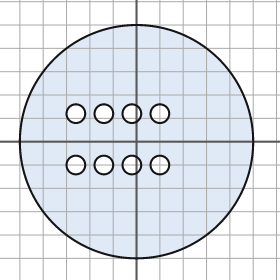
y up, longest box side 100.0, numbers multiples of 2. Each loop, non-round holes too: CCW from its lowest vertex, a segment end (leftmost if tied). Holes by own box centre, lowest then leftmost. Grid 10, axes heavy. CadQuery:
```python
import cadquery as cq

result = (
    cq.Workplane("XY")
    .moveTo(0.0, 0.0)
    .circle(50.0)
    .moveTo(-26.0, -10.0)
    .circle(4.0)
    .moveTo(-14.0, -10.0)
    .circle(4.0)
    .moveTo(-2.0, -10.0)
    .circle(4.0)
    .moveTo(10.0, -10.0)
    .circle(4.0)
    .moveTo(-26.0, 12.0)
    .circle(4.0)
    .moveTo(-14.0, 12.0)
    .circle(4.0)
    .moveTo(-2.0, 12.0)
    .circle(4.0)
    .moveTo(10.0, 12.0)
    .circle(4.0)
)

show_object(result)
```